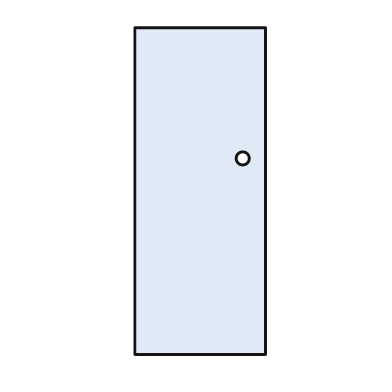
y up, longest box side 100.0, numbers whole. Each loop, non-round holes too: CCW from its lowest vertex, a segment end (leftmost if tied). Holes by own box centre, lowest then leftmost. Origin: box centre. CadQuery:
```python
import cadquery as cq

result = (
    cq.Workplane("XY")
    .moveTo(-20.0, -50.0)
    .lineTo(20.0, -50.0)
    .lineTo(20.0, 50.0)
    .lineTo(-20.0, 50.0)
    .close()
    .moveTo(13.0, 10.0)
    .circle(2.0)
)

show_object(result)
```